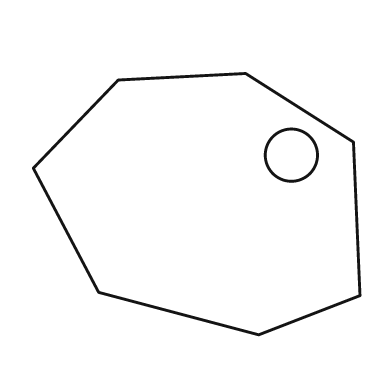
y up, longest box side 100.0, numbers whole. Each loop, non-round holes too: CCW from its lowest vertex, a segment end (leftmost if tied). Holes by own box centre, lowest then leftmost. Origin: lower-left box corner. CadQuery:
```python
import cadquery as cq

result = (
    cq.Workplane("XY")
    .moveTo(69.0, 0.0)
    .lineTo(100.0, 12.0)
    .lineTo(98.0, 59.0)
    .lineTo(65.0, 80.0)
    .lineTo(26.0, 78.0)
    .lineTo(0.0, 51.0)
    .lineTo(20.0, 13.0)
    .close()
    .moveTo(79.0, 55.0)
    .circle(8.0)
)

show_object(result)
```